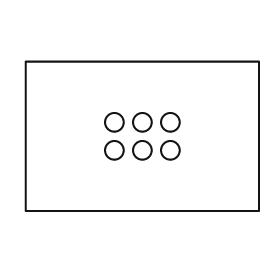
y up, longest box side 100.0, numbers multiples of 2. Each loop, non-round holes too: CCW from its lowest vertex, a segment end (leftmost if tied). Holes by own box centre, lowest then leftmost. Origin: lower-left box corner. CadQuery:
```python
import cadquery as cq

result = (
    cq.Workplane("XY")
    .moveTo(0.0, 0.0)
    .lineTo(100.0, 0.0)
    .lineTo(100.0, 64.0)
    .lineTo(0.0, 64.0)
    .close()
    .moveTo(38.0, 26.0)
    .circle(4.0)
    .moveTo(50.0, 26.0)
    .circle(4.0)
    .moveTo(62.0, 26.0)
    .circle(4.0)
    .moveTo(38.0, 38.0)
    .circle(4.0)
    .moveTo(50.0, 38.0)
    .circle(4.0)
    .moveTo(62.0, 38.0)
    .circle(4.0)
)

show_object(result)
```